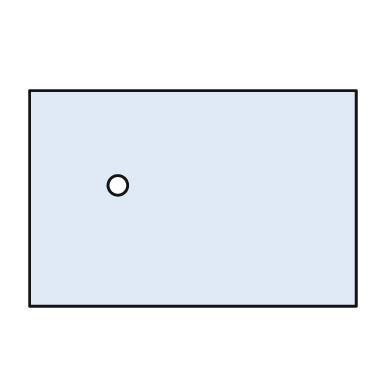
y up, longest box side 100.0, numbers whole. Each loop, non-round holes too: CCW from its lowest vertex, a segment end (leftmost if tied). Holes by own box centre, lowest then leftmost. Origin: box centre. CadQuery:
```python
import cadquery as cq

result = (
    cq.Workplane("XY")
    .moveTo(-50.0, -33.0)
    .lineTo(50.0, -33.0)
    .lineTo(50.0, 33.0)
    .lineTo(-50.0, 33.0)
    .close()
    .moveTo(-23.0, 4.0)
    .circle(3.0)
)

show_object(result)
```